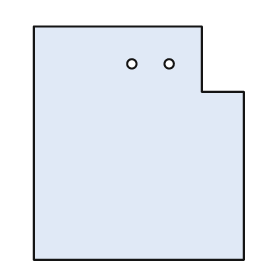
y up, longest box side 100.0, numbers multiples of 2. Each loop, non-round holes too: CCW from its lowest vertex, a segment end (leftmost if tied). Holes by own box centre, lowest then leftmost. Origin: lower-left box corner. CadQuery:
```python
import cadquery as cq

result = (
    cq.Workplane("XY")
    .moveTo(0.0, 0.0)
    .lineTo(90.0, 0.0)
    .lineTo(90.0, 72.0)
    .lineTo(72.0, 72.0)
    .lineTo(72.0, 100.0)
    .lineTo(0.0, 100.0)
    .close()
    .moveTo(42.0, 84.0)
    .circle(2.0)
    .moveTo(58.0, 84.0)
    .circle(2.0)
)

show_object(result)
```